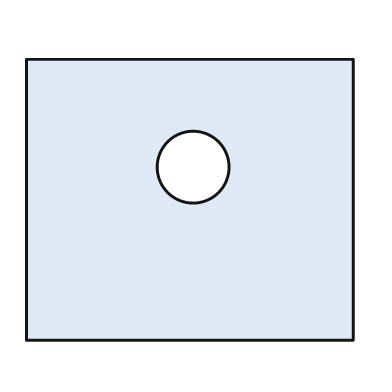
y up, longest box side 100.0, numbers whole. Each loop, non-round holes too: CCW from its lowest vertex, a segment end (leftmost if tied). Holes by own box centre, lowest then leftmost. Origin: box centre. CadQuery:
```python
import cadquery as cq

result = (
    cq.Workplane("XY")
    .moveTo(-50.0, -43.0)
    .lineTo(50.0, -43.0)
    .lineTo(50.0, 43.0)
    .lineTo(-50.0, 43.0)
    .close()
    .moveTo(1.0, 10.0)
    .circle(11.0)
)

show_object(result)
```